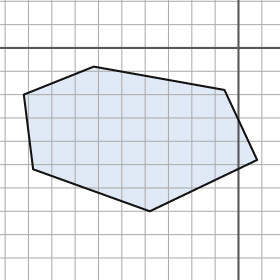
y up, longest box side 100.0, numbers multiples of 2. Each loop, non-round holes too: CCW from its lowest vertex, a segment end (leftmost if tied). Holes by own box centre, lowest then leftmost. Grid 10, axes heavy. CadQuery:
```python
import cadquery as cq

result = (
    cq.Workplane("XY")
    .moveTo(-38.0, -70.0)
    .lineTo(8.0, -48.0)
    .lineTo(-6.0, -18.0)
    .lineTo(-62.0, -8.0)
    .lineTo(-92.0, -20.0)
    .lineTo(-88.0, -52.0)
    .close()
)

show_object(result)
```